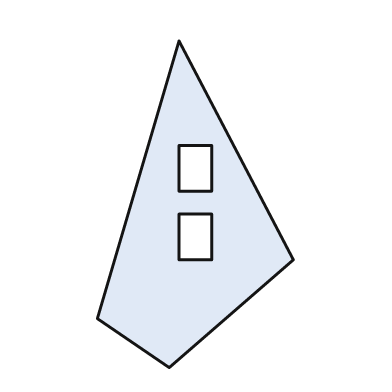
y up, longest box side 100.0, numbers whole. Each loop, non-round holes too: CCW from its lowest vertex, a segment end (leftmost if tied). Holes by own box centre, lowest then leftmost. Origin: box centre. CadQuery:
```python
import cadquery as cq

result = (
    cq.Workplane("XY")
    .moveTo(-8.0, -50.0)
    .lineTo(30.0, -17.0)
    .lineTo(-5.0, 50.0)
    .lineTo(-30.0, -35.0)
    .close()
    .moveTo(-5.0, -17.0)
    .lineTo(5.0, -17.0)
    .lineTo(5.0, -3.0)
    .lineTo(-5.0, -3.0)
    .close()
    .moveTo(-5.0, 4.0)
    .lineTo(5.0, 4.0)
    .lineTo(5.0, 18.0)
    .lineTo(-5.0, 18.0)
    .close()
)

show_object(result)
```